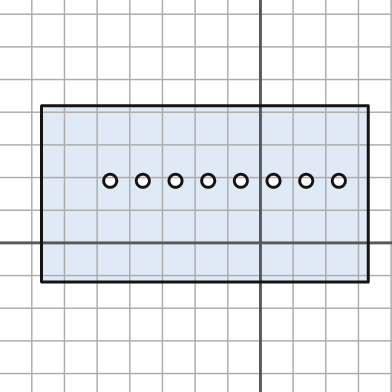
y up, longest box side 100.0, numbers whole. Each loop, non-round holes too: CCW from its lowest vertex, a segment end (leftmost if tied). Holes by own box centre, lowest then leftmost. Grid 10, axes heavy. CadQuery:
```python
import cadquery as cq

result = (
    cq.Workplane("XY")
    .moveTo(-67.0, -12.0)
    .lineTo(33.0, -12.0)
    .lineTo(33.0, 42.0)
    .lineTo(-67.0, 42.0)
    .close()
    .moveTo(-46.0, 19.0)
    .circle(2.0)
    .moveTo(-36.0, 19.0)
    .circle(2.0)
    .moveTo(-26.0, 19.0)
    .circle(2.0)
    .moveTo(-16.0, 19.0)
    .circle(2.0)
    .moveTo(-6.0, 19.0)
    .circle(2.0)
    .moveTo(4.0, 19.0)
    .circle(2.0)
    .moveTo(14.0, 19.0)
    .circle(2.0)
    .moveTo(24.0, 19.0)
    .circle(2.0)
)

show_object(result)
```